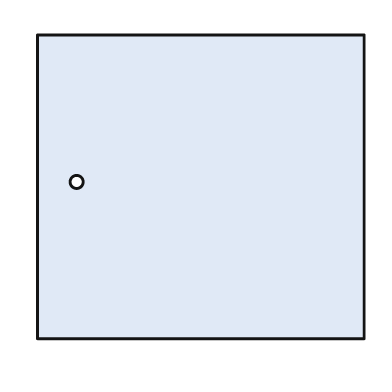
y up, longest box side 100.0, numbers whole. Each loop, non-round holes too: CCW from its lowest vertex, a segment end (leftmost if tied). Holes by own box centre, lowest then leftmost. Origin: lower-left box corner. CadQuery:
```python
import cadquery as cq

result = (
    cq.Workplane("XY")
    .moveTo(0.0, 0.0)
    .lineTo(100.0, 0.0)
    .lineTo(100.0, 93.0)
    .lineTo(0.0, 93.0)
    .close()
    .moveTo(12.0, 48.0)
    .circle(2.0)
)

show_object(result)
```